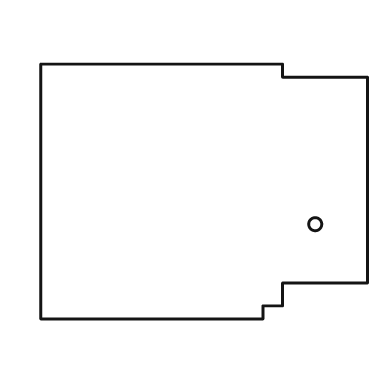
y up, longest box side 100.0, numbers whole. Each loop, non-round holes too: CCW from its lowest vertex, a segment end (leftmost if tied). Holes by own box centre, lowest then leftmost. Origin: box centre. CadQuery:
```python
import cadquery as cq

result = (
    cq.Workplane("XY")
    .moveTo(-50.0, -39.0)
    .lineTo(18.0, -39.0)
    .lineTo(18.0, -35.0)
    .lineTo(24.0, -35.0)
    .lineTo(24.0, -28.0)
    .lineTo(50.0, -28.0)
    .lineTo(50.0, 35.0)
    .lineTo(24.0, 35.0)
    .lineTo(24.0, 39.0)
    .lineTo(-50.0, 39.0)
    .close()
    .moveTo(34.0, -10.0)
    .circle(2.0)
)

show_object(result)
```